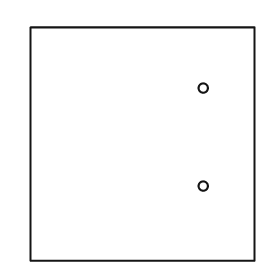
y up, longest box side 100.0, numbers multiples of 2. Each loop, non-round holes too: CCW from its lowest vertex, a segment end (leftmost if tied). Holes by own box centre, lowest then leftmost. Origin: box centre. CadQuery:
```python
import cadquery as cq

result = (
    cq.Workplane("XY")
    .moveTo(-48.0, -50.0)
    .lineTo(48.0, -50.0)
    .lineTo(48.0, 50.0)
    .lineTo(-48.0, 50.0)
    .close()
    .moveTo(26.0, -18.0)
    .circle(2.0)
    .moveTo(26.0, 24.0)
    .circle(2.0)
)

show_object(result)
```